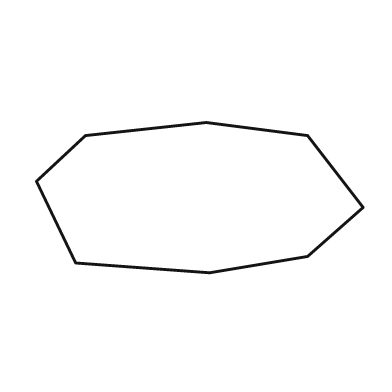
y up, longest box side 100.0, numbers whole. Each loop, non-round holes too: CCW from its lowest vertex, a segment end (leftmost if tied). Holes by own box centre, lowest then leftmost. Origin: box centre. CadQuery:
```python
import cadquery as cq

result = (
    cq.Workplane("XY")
    .moveTo(3.0, -23.0)
    .lineTo(33.0, -18.0)
    .lineTo(50.0, -3.0)
    .lineTo(33.0, 19.0)
    .lineTo(2.0, 23.0)
    .lineTo(-35.0, 19.0)
    .lineTo(-50.0, 5.0)
    .lineTo(-38.0, -20.0)
    .close()
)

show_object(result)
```